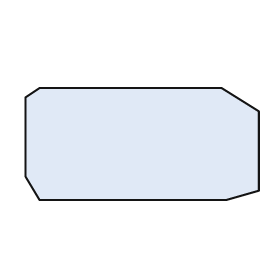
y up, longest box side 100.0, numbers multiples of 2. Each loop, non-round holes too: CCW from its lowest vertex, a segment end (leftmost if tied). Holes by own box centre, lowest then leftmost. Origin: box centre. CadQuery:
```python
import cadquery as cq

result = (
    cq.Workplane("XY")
    .moveTo(-44.0, -24.0)
    .lineTo(36.0, -24.0)
    .lineTo(50.0, -20.0)
    .lineTo(50.0, 14.0)
    .lineTo(34.0, 24.0)
    .lineTo(-44.0, 24.0)
    .lineTo(-50.0, 20.0)
    .lineTo(-50.0, -14.0)
    .close()
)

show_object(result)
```